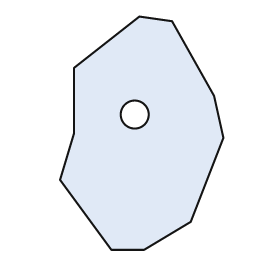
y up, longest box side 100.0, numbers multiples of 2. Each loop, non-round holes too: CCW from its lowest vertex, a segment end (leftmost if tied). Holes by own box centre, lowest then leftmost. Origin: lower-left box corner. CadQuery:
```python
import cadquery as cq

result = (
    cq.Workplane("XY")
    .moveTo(22.0, 0.0)
    .lineTo(36.0, 0.0)
    .lineTo(56.0, 12.0)
    .lineTo(70.0, 48.0)
    .lineTo(66.0, 66.0)
    .lineTo(48.0, 98.0)
    .lineTo(34.0, 100.0)
    .lineTo(6.0, 78.0)
    .lineTo(6.0, 50.0)
    .lineTo(0.0, 30.0)
    .close()
    .moveTo(32.0, 58.0)
    .circle(6.0)
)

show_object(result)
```